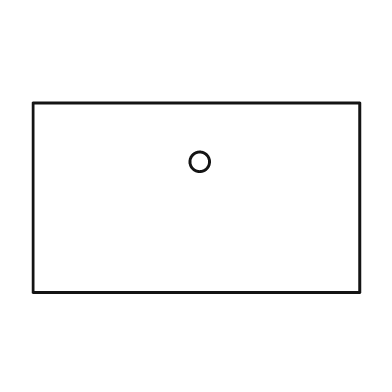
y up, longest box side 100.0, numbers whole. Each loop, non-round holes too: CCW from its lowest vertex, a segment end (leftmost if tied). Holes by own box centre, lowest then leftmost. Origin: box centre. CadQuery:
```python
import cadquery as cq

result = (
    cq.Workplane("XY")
    .moveTo(-50.0, -29.0)
    .lineTo(50.0, -29.0)
    .lineTo(50.0, 29.0)
    .lineTo(-50.0, 29.0)
    .close()
    .moveTo(1.0, 11.0)
    .circle(3.0)
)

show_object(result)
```